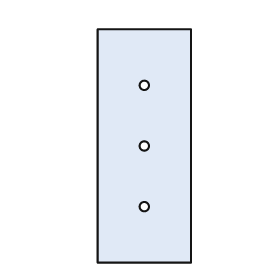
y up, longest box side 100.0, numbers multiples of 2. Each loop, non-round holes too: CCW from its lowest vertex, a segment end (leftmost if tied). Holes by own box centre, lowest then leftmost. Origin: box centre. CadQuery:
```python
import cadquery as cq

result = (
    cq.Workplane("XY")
    .moveTo(-20.0, -50.0)
    .lineTo(20.0, -50.0)
    .lineTo(20.0, 50.0)
    .lineTo(-20.0, 50.0)
    .close()
    .moveTo(0.0, -26.0)
    .circle(2.0)
    .moveTo(0.0, 0.0)
    .circle(2.0)
    .moveTo(0.0, 26.0)
    .circle(2.0)
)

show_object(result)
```